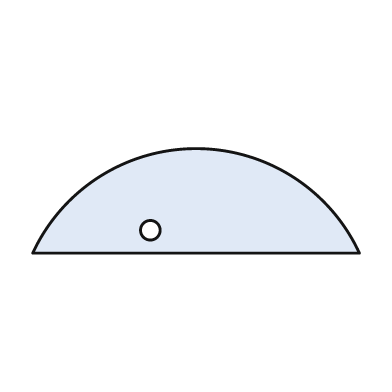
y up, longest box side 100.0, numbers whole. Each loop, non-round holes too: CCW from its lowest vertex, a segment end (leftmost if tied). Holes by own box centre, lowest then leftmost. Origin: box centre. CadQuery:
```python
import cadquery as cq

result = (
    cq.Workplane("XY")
    .moveTo(-50.0, -16.0)
    .lineTo(50.0, -16.0)
    .threePointArc((0.0, 16.0), (-50.0, -16.0))
    .close()
    .moveTo(-14.0, -9.0)
    .circle(3.0)
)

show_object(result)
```